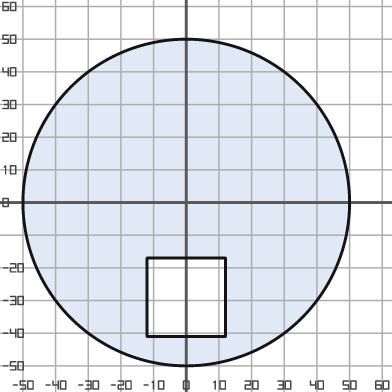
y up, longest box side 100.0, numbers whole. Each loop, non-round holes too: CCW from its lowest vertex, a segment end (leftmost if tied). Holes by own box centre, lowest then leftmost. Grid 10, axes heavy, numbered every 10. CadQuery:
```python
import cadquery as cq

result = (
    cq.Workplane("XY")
    .moveTo(0.0, 0.0)
    .circle(50.0)
    .moveTo(-12.0, -41.0)
    .lineTo(12.0, -41.0)
    .lineTo(12.0, -17.0)
    .lineTo(-12.0, -17.0)
    .close()
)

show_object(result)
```